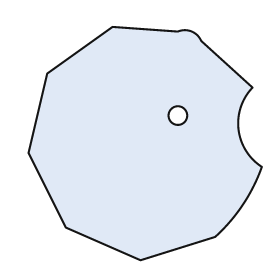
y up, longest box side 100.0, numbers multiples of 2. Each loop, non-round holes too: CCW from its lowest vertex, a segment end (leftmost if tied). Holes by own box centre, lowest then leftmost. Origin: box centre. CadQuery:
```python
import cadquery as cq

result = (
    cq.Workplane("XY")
    .moveTo(-2.0, -50.0)
    .lineTo(30.0, -40.0)
    .threePointArc((42.0, -26.0), (50.0, -10.0))
    .threePointArc((40.0, 6.0), (46.0, 24.0))
    .lineTo(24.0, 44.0)
    .threePointArc((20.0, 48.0), (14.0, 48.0))
    .lineTo(-14.0, 50.0)
    .lineTo(-42.0, 30.0)
    .lineTo(-50.0, -4.0)
    .lineTo(-34.0, -36.0)
    .close()
    .moveTo(14.0, 12.0)
    .circle(4.0)
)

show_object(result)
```